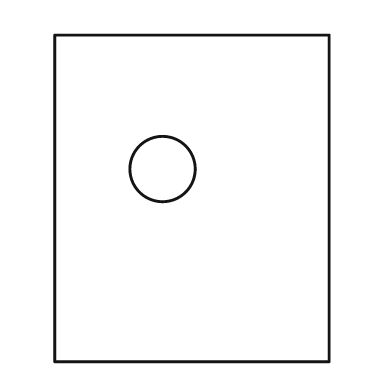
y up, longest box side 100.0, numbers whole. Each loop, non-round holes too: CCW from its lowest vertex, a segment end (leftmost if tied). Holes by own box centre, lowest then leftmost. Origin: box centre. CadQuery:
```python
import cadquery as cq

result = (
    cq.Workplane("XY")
    .moveTo(-42.0, -50.0)
    .lineTo(42.0, -50.0)
    .lineTo(42.0, 50.0)
    .lineTo(-42.0, 50.0)
    .close()
    .moveTo(-9.0, 9.0)
    .circle(10.0)
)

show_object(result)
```